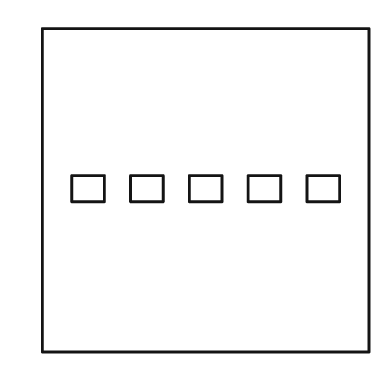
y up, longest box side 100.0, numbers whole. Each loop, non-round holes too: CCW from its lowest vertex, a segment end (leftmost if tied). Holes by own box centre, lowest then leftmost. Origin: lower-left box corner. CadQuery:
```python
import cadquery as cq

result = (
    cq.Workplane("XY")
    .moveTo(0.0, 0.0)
    .lineTo(100.0, 0.0)
    .lineTo(100.0, 99.0)
    .lineTo(0.0, 99.0)
    .close()
    .moveTo(9.0, 46.0)
    .lineTo(19.0, 46.0)
    .lineTo(19.0, 54.0)
    .lineTo(9.0, 54.0)
    .close()
    .moveTo(27.0, 46.0)
    .lineTo(37.0, 46.0)
    .lineTo(37.0, 54.0)
    .lineTo(27.0, 54.0)
    .close()
    .moveTo(45.0, 46.0)
    .lineTo(55.0, 46.0)
    .lineTo(55.0, 54.0)
    .lineTo(45.0, 54.0)
    .close()
    .moveTo(63.0, 46.0)
    .lineTo(73.0, 46.0)
    .lineTo(73.0, 54.0)
    .lineTo(63.0, 54.0)
    .close()
    .moveTo(81.0, 46.0)
    .lineTo(91.0, 46.0)
    .lineTo(91.0, 54.0)
    .lineTo(81.0, 54.0)
    .close()
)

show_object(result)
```